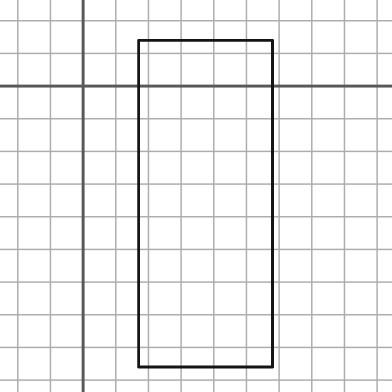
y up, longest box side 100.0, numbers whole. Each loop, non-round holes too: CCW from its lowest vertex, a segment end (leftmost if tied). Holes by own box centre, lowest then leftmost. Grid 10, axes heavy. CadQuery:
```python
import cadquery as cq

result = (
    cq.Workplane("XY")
    .moveTo(17.0, -86.0)
    .lineTo(58.0, -86.0)
    .lineTo(58.0, 14.0)
    .lineTo(17.0, 14.0)
    .close()
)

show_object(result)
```